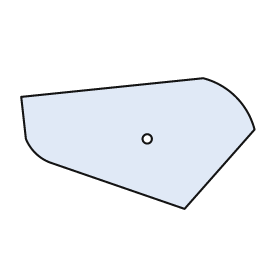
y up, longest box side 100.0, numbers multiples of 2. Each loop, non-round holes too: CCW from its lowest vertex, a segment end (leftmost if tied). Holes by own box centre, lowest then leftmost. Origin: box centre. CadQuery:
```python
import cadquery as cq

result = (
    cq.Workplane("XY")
    .moveTo(20.0, -28.0)
    .lineTo(50.0, 6.0)
    .threePointArc((42.0, 20.0), (28.0, 28.0))
    .lineTo(-50.0, 20.0)
    .lineTo(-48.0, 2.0)
    .threePointArc((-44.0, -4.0), (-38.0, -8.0))
    .close()
    .moveTo(4.0, 2.0)
    .circle(2.0)
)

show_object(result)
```